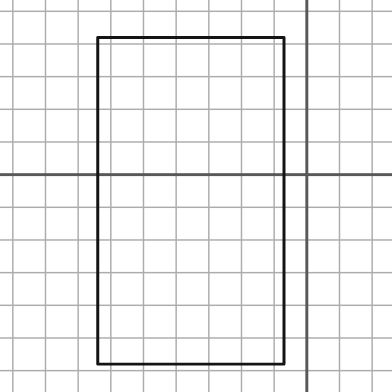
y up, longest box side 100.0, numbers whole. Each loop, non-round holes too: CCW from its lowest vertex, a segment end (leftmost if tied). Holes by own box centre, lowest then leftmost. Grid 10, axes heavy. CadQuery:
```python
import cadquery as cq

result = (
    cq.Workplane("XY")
    .moveTo(-64.0, -58.0)
    .lineTo(-7.0, -58.0)
    .lineTo(-7.0, 42.0)
    .lineTo(-64.0, 42.0)
    .close()
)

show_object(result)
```